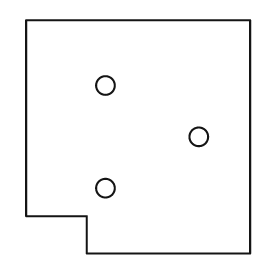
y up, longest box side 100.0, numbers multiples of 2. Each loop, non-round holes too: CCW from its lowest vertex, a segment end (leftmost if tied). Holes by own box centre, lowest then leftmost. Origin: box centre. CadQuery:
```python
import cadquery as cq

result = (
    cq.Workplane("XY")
    .moveTo(-22.0, -50.0)
    .lineTo(48.0, -50.0)
    .lineTo(48.0, 50.0)
    .lineTo(-48.0, 50.0)
    .lineTo(-48.0, -34.0)
    .lineTo(-22.0, -34.0)
    .close()
    .moveTo(-14.0, -22.0)
    .circle(4.0)
    .moveTo(26.0, 0.0)
    .circle(4.0)
    .moveTo(-14.0, 22.0)
    .circle(4.0)
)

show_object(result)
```